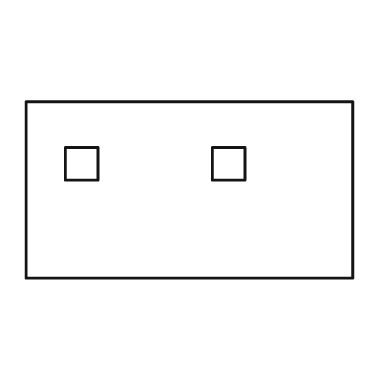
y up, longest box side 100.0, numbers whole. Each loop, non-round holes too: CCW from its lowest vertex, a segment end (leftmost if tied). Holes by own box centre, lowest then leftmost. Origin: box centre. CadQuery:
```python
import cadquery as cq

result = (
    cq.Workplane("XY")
    .moveTo(-50.0, -27.0)
    .lineTo(50.0, -27.0)
    .lineTo(50.0, 27.0)
    .lineTo(-50.0, 27.0)
    .close()
    .moveTo(-38.0, 3.0)
    .lineTo(-28.0, 3.0)
    .lineTo(-28.0, 13.0)
    .lineTo(-38.0, 13.0)
    .close()
    .moveTo(7.0, 3.0)
    .lineTo(17.0, 3.0)
    .lineTo(17.0, 13.0)
    .lineTo(7.0, 13.0)
    .close()
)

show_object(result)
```